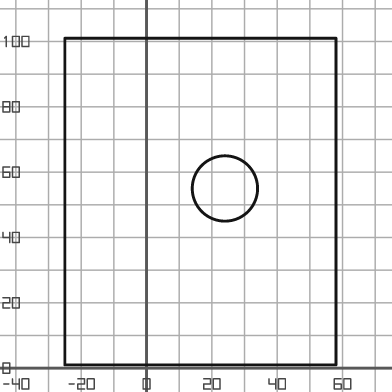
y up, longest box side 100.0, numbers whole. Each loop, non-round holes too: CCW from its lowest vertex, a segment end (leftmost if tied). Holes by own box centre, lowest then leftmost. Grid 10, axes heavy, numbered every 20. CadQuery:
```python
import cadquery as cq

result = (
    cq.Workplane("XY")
    .moveTo(-25.0, 1.0)
    .lineTo(58.0, 1.0)
    .lineTo(58.0, 101.0)
    .lineTo(-25.0, 101.0)
    .close()
    .moveTo(24.0, 55.0)
    .circle(10.0)
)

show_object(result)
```